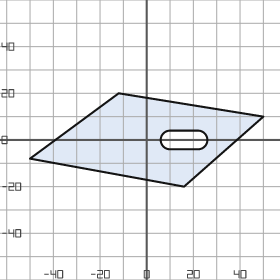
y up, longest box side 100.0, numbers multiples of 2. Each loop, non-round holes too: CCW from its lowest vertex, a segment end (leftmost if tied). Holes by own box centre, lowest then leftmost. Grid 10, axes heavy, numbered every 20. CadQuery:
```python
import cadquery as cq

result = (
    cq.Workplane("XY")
    .moveTo(16.0, -20.0)
    .lineTo(50.0, 10.0)
    .lineTo(-12.0, 20.0)
    .lineTo(-50.0, -8.0)
    .close()
    .moveTo(10.0, -4.0)
    .lineTo(22.0, -4.0)
    .threePointArc((26.0, 0.0), (22.0, 4.0))
    .lineTo(10.0, 4.0)
    .threePointArc((6.0, 0.0), (10.0, -4.0))
    .close()
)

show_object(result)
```